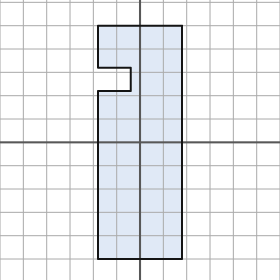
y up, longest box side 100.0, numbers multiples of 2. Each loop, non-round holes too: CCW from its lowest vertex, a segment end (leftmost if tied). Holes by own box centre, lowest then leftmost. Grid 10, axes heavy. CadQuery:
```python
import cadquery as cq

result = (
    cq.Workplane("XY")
    .moveTo(-18.0, -50.0)
    .lineTo(18.0, -50.0)
    .lineTo(18.0, 50.0)
    .lineTo(-18.0, 50.0)
    .lineTo(-18.0, 32.0)
    .lineTo(-4.0, 32.0)
    .lineTo(-4.0, 22.0)
    .lineTo(-18.0, 22.0)
    .close()
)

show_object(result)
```